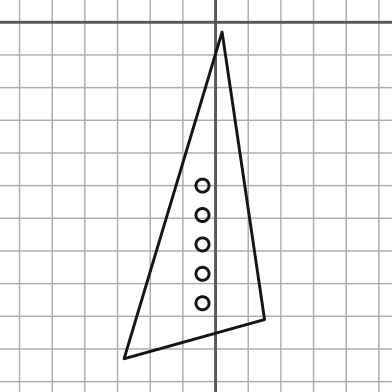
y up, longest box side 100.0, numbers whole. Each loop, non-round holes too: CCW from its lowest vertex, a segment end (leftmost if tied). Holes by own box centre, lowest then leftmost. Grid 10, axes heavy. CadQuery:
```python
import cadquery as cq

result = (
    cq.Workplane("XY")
    .moveTo(-28.0, -103.0)
    .lineTo(15.0, -91.0)
    .lineTo(2.0, -3.0)
    .close()
    .moveTo(-4.0, -86.0)
    .circle(2.0)
    .moveTo(-4.0, -77.0)
    .circle(2.0)
    .moveTo(-4.0, -68.0)
    .circle(2.0)
    .moveTo(-4.0, -59.0)
    .circle(2.0)
    .moveTo(-4.0, -50.0)
    .circle(2.0)
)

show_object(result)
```